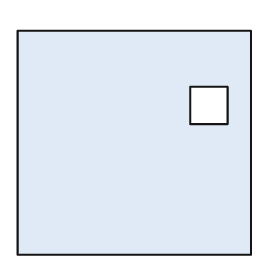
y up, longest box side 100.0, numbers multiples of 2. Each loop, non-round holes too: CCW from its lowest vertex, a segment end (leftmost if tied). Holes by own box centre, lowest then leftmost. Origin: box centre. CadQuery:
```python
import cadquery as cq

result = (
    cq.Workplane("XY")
    .moveTo(-50.0, -48.0)
    .lineTo(50.0, -48.0)
    .lineTo(50.0, 48.0)
    .lineTo(-50.0, 48.0)
    .close()
    .moveTo(24.0, 8.0)
    .lineTo(40.0, 8.0)
    .lineTo(40.0, 24.0)
    .lineTo(24.0, 24.0)
    .close()
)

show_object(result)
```